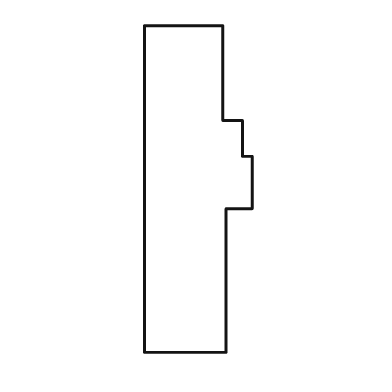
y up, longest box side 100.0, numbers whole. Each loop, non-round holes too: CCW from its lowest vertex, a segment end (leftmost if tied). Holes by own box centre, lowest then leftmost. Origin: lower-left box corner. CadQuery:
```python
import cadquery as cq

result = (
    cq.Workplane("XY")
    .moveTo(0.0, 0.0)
    .lineTo(25.0, 0.0)
    .lineTo(25.0, 44.0)
    .lineTo(33.0, 44.0)
    .lineTo(33.0, 60.0)
    .lineTo(30.0, 60.0)
    .lineTo(30.0, 71.0)
    .lineTo(24.0, 71.0)
    .lineTo(24.0, 100.0)
    .lineTo(0.0, 100.0)
    .close()
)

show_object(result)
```